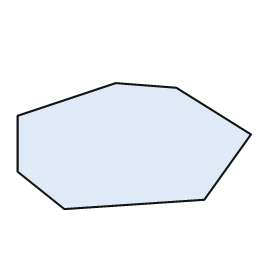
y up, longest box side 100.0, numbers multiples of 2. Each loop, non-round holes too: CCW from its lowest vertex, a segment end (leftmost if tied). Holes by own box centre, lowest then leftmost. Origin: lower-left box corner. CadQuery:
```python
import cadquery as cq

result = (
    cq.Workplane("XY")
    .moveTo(20.0, 0.0)
    .lineTo(80.0, 4.0)
    .lineTo(100.0, 32.0)
    .lineTo(68.0, 52.0)
    .lineTo(42.0, 54.0)
    .lineTo(0.0, 40.0)
    .lineTo(0.0, 16.0)
    .close()
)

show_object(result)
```